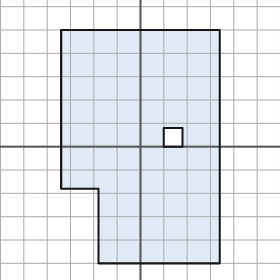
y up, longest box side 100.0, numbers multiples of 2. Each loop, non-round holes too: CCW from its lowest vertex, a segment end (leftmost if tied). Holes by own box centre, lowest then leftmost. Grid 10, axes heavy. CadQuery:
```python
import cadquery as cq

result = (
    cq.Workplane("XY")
    .moveTo(-18.0, -50.0)
    .lineTo(34.0, -50.0)
    .lineTo(34.0, 50.0)
    .lineTo(-34.0, 50.0)
    .lineTo(-34.0, -18.0)
    .lineTo(-18.0, -18.0)
    .close()
    .moveTo(10.0, 0.0)
    .lineTo(18.0, 0.0)
    .lineTo(18.0, 8.0)
    .lineTo(10.0, 8.0)
    .close()
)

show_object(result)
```